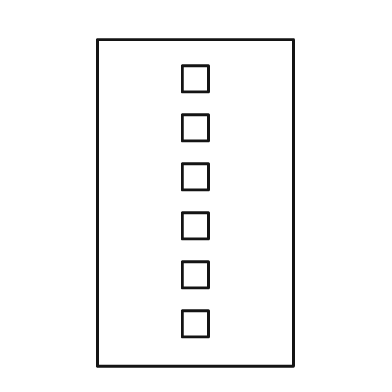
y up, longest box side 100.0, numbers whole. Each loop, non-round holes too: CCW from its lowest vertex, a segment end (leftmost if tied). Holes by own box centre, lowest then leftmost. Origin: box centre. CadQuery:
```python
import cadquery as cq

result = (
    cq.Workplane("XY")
    .moveTo(-30.0, -50.0)
    .lineTo(30.0, -50.0)
    .lineTo(30.0, 50.0)
    .lineTo(-30.0, 50.0)
    .close()
    .moveTo(-4.0, -41.0)
    .lineTo(4.0, -41.0)
    .lineTo(4.0, -33.0)
    .lineTo(-4.0, -33.0)
    .close()
    .moveTo(-4.0, -26.0)
    .lineTo(4.0, -26.0)
    .lineTo(4.0, -18.0)
    .lineTo(-4.0, -18.0)
    .close()
    .moveTo(-4.0, -11.0)
    .lineTo(4.0, -11.0)
    .lineTo(4.0, -3.0)
    .lineTo(-4.0, -3.0)
    .close()
    .moveTo(-4.0, 4.0)
    .lineTo(4.0, 4.0)
    .lineTo(4.0, 12.0)
    .lineTo(-4.0, 12.0)
    .close()
    .moveTo(-4.0, 19.0)
    .lineTo(4.0, 19.0)
    .lineTo(4.0, 27.0)
    .lineTo(-4.0, 27.0)
    .close()
    .moveTo(-4.0, 34.0)
    .lineTo(4.0, 34.0)
    .lineTo(4.0, 42.0)
    .lineTo(-4.0, 42.0)
    .close()
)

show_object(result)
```